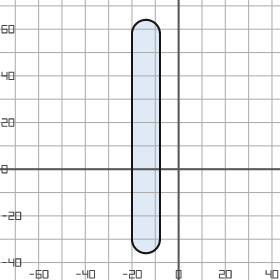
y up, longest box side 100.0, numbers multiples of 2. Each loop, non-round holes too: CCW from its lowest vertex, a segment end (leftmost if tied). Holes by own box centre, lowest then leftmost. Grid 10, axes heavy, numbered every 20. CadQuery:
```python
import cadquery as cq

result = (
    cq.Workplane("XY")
    .moveTo(-20.0, -30.0)
    .threePointArc((-14.0, -36.0), (-8.0, -30.0))
    .lineTo(-8.0, 58.0)
    .threePointArc((-14.0, 64.0), (-20.0, 58.0))
    .close()
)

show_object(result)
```